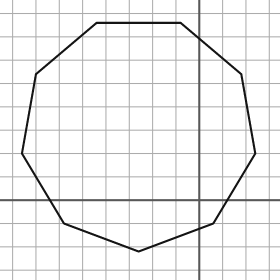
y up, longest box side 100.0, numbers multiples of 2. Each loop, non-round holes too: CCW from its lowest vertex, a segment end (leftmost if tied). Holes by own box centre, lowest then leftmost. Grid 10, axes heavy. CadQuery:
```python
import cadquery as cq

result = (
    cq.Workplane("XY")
    .moveTo(-26.0, -22.0)
    .lineTo(6.0, -10.0)
    .lineTo(24.0, 20.0)
    .lineTo(18.0, 54.0)
    .lineTo(-8.0, 76.0)
    .lineTo(-44.0, 76.0)
    .lineTo(-70.0, 54.0)
    .lineTo(-76.0, 20.0)
    .lineTo(-58.0, -10.0)
    .close()
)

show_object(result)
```